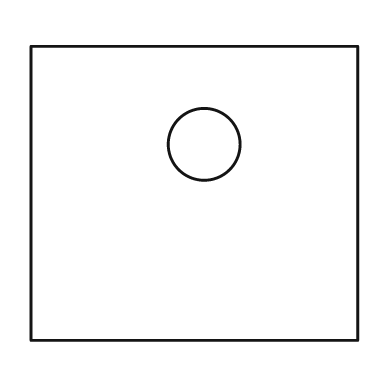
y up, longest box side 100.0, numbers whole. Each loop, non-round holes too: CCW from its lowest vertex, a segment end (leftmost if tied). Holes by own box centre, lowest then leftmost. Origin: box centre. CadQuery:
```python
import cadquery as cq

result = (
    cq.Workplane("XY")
    .moveTo(-50.0, -45.0)
    .lineTo(50.0, -45.0)
    .lineTo(50.0, 45.0)
    .lineTo(-50.0, 45.0)
    .close()
    .moveTo(3.0, 15.0)
    .circle(11.0)
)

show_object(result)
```